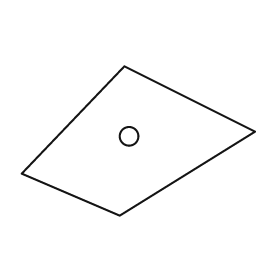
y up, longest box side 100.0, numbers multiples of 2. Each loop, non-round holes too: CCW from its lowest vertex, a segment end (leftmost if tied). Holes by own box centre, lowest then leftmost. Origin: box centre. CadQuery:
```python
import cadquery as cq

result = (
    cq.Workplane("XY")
    .moveTo(-8.0, -32.0)
    .lineTo(50.0, 4.0)
    .lineTo(-6.0, 32.0)
    .lineTo(-50.0, -14.0)
    .close()
    .moveTo(-4.0, 2.0)
    .circle(4.0)
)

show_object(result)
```